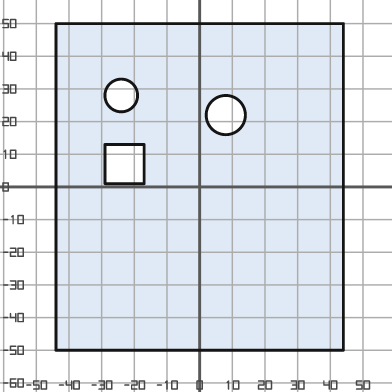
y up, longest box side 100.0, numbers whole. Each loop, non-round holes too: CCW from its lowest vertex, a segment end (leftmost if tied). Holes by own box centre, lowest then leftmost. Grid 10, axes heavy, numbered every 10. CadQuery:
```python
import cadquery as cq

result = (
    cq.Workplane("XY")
    .moveTo(-44.0, -50.0)
    .lineTo(44.0, -50.0)
    .lineTo(44.0, 50.0)
    .lineTo(-44.0, 50.0)
    .close()
    .moveTo(-29.0, 1.0)
    .lineTo(-17.0, 1.0)
    .lineTo(-17.0, 13.0)
    .lineTo(-29.0, 13.0)
    .close()
    .moveTo(8.0, 22.0)
    .circle(6.0)
    .moveTo(-24.0, 28.0)
    .circle(5.0)
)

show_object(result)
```